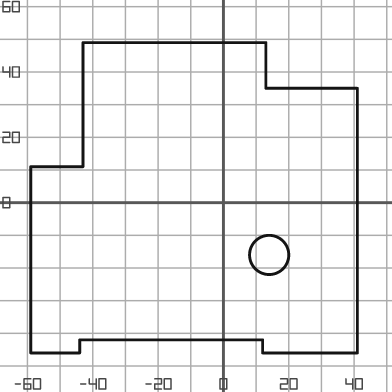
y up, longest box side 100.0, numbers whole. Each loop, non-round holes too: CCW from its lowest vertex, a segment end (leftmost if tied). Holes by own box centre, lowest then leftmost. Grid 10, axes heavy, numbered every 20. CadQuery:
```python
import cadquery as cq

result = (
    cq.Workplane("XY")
    .moveTo(-59.0, -46.0)
    .lineTo(-44.0, -46.0)
    .lineTo(-44.0, -42.0)
    .lineTo(12.0, -42.0)
    .lineTo(12.0, -46.0)
    .lineTo(41.0, -46.0)
    .lineTo(41.0, 35.0)
    .lineTo(13.0, 35.0)
    .lineTo(13.0, 49.0)
    .lineTo(-43.0, 49.0)
    .lineTo(-43.0, 11.0)
    .lineTo(-59.0, 11.0)
    .close()
    .moveTo(14.0, -16.0)
    .circle(6.0)
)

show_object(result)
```